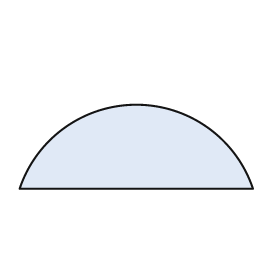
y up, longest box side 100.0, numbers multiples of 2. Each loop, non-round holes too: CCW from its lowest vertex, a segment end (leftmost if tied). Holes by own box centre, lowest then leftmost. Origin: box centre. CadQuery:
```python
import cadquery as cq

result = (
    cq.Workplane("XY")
    .moveTo(-50.0, -18.0)
    .lineTo(50.0, -18.0)
    .threePointArc((0.0, 18.0), (-50.0, -18.0))
    .close()
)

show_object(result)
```